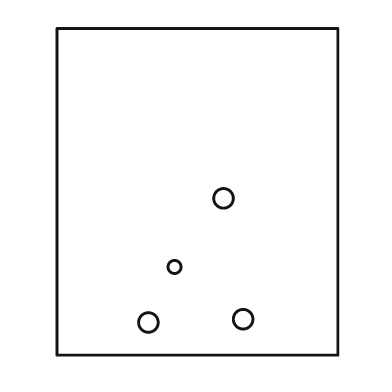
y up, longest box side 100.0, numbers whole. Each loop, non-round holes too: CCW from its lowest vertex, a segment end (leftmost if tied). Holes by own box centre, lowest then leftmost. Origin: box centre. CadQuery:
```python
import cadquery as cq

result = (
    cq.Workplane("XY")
    .moveTo(-43.0, -50.0)
    .lineTo(43.0, -50.0)
    .lineTo(43.0, 50.0)
    .lineTo(-43.0, 50.0)
    .close()
    .moveTo(-15.0, -40.0)
    .circle(3.0)
    .moveTo(14.0, -39.0)
    .circle(3.0)
    .moveTo(-7.0, -23.0)
    .circle(2.0)
    .moveTo(8.0, -2.0)
    .circle(3.0)
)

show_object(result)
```